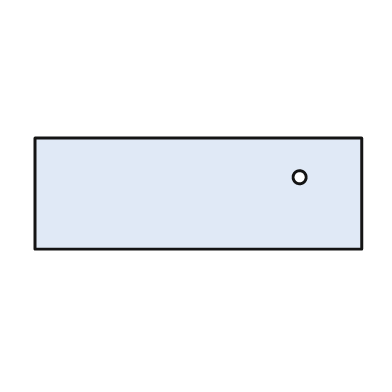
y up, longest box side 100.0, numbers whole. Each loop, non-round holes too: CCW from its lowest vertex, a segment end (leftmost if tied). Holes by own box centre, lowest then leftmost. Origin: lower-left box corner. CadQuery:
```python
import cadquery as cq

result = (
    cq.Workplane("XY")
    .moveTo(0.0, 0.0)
    .lineTo(100.0, 0.0)
    .lineTo(100.0, 34.0)
    .lineTo(0.0, 34.0)
    .close()
    .moveTo(81.0, 22.0)
    .circle(2.0)
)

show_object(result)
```